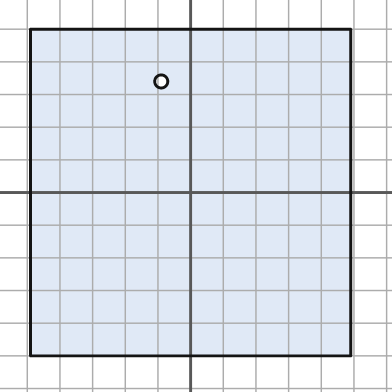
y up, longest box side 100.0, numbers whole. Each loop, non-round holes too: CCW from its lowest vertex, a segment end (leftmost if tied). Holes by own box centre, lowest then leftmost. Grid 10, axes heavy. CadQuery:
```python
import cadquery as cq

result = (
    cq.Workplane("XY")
    .moveTo(-49.0, -50.0)
    .lineTo(49.0, -50.0)
    .lineTo(49.0, 50.0)
    .lineTo(-49.0, 50.0)
    .close()
    .moveTo(-9.0, 34.0)
    .circle(2.0)
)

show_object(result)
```